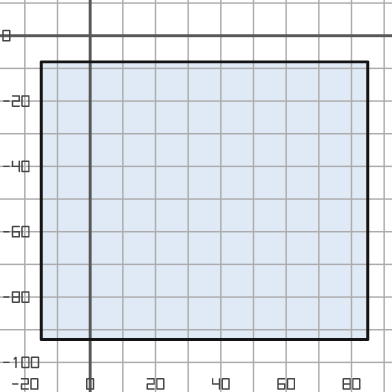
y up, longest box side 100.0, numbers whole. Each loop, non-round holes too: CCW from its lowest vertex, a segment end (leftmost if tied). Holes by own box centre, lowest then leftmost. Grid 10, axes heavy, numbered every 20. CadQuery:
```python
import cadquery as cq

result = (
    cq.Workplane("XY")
    .moveTo(-15.0, -93.0)
    .lineTo(85.0, -93.0)
    .lineTo(85.0, -8.0)
    .lineTo(-15.0, -8.0)
    .close()
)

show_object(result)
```